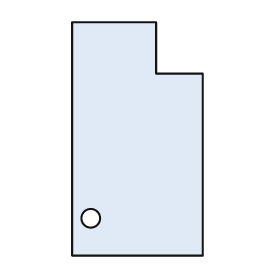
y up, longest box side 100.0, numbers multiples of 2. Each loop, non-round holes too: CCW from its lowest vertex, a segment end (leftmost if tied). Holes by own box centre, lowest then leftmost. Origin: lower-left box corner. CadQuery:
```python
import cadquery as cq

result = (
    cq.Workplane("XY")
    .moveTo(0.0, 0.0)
    .lineTo(56.0, 0.0)
    .lineTo(56.0, 78.0)
    .lineTo(36.0, 78.0)
    .lineTo(36.0, 100.0)
    .lineTo(0.0, 100.0)
    .close()
    .moveTo(8.0, 16.0)
    .circle(4.0)
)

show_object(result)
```